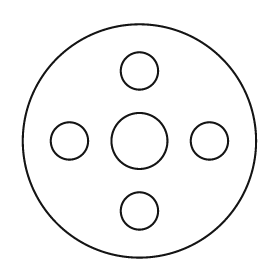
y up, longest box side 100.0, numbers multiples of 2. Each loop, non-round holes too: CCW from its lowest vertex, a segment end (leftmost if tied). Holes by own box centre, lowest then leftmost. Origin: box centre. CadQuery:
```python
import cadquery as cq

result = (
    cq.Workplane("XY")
    .moveTo(0.0, 0.0)
    .circle(50.0)
    .moveTo(0.0, -30.0)
    .circle(8.0)
    .moveTo(-30.0, 0.0)
    .circle(8.0)
    .moveTo(0.0, 0.0)
    .circle(12.0)
    .moveTo(30.0, 0.0)
    .circle(8.0)
    .moveTo(0.0, 30.0)
    .circle(8.0)
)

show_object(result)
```